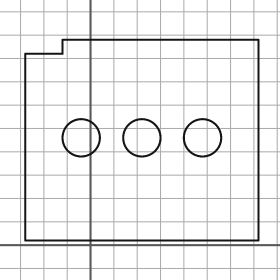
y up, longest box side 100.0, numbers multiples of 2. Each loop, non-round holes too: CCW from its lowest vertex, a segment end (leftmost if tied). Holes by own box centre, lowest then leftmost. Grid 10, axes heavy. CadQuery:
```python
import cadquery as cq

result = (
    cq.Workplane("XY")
    .moveTo(-28.0, 2.0)
    .lineTo(72.0, 2.0)
    .lineTo(72.0, 88.0)
    .lineTo(-12.0, 88.0)
    .lineTo(-12.0, 82.0)
    .lineTo(-28.0, 82.0)
    .close()
    .moveTo(-4.0, 46.0)
    .circle(8.0)
    .moveTo(22.0, 46.0)
    .circle(8.0)
    .moveTo(48.0, 46.0)
    .circle(8.0)
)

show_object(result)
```